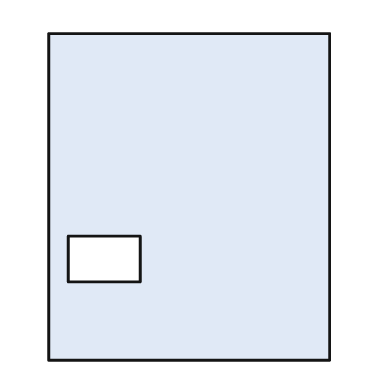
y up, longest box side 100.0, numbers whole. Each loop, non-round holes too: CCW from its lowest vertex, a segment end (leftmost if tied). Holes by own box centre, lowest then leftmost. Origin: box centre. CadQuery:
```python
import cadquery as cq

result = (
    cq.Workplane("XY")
    .moveTo(-43.0, -50.0)
    .lineTo(43.0, -50.0)
    .lineTo(43.0, 50.0)
    .lineTo(-43.0, 50.0)
    .close()
    .moveTo(-37.0, -26.0)
    .lineTo(-15.0, -26.0)
    .lineTo(-15.0, -12.0)
    .lineTo(-37.0, -12.0)
    .close()
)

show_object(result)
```